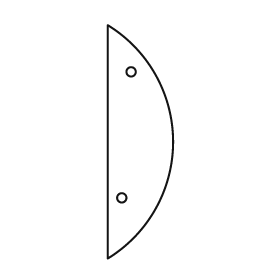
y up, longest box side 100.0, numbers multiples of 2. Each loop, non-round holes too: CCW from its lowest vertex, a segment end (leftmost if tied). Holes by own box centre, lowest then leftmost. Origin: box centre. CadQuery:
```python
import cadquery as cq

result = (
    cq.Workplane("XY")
    .moveTo(-14.0, -50.0)
    .threePointArc((14.0, 0.0), (-14.0, 50.0))
    .close()
    .moveTo(-8.0, -24.0)
    .circle(2.0)
    .moveTo(-4.0, 30.0)
    .circle(2.0)
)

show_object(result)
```